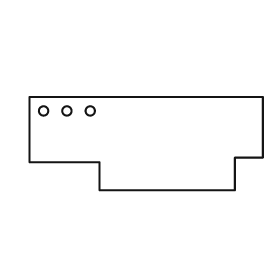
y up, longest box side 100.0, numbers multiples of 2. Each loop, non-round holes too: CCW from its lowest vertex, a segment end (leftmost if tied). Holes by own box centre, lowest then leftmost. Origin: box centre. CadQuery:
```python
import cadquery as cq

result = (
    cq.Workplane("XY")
    .moveTo(-20.0, -20.0)
    .lineTo(38.0, -20.0)
    .lineTo(38.0, -6.0)
    .lineTo(50.0, -6.0)
    .lineTo(50.0, 20.0)
    .lineTo(-50.0, 20.0)
    .lineTo(-50.0, -8.0)
    .lineTo(-20.0, -8.0)
    .close()
    .moveTo(-44.0, 14.0)
    .circle(2.0)
    .moveTo(-34.0, 14.0)
    .circle(2.0)
    .moveTo(-24.0, 14.0)
    .circle(2.0)
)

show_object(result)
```